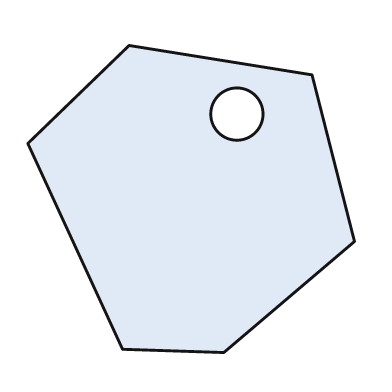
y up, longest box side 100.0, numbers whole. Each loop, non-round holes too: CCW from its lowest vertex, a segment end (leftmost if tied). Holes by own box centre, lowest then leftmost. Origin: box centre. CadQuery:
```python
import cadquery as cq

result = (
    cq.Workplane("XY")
    .moveTo(10.0, -47.0)
    .lineTo(50.0, -13.0)
    .lineTo(37.0, 38.0)
    .lineTo(-19.0, 47.0)
    .lineTo(-50.0, 17.0)
    .lineTo(-21.0, -46.0)
    .close()
    .moveTo(14.0, 26.0)
    .circle(8.0)
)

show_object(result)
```